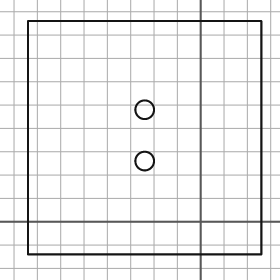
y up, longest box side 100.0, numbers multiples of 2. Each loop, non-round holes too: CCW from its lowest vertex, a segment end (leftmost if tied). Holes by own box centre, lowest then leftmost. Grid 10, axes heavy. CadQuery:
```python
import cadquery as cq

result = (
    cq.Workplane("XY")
    .moveTo(-74.0, -14.0)
    .lineTo(26.0, -14.0)
    .lineTo(26.0, 86.0)
    .lineTo(-74.0, 86.0)
    .close()
    .moveTo(-24.0, 26.0)
    .circle(4.0)
    .moveTo(-24.0, 48.0)
    .circle(4.0)
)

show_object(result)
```